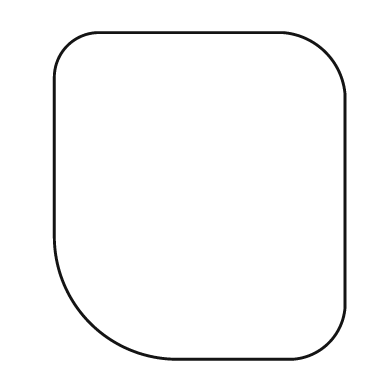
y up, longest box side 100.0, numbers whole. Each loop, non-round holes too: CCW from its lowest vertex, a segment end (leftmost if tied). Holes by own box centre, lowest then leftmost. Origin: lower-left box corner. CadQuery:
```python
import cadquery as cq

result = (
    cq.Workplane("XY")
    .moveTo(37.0, 0.0)
    .lineTo(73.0, 0.0)
    .threePointArc((84.0, 5.0), (89.0, 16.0))
    .lineTo(89.0, 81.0)
    .threePointArc((83.0, 94.0), (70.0, 100.0))
    .lineTo(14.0, 100.0)
    .threePointArc((4.0, 96.0), (0.0, 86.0))
    .lineTo(0.0, 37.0)
    .threePointArc((11.0, 11.0), (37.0, 0.0))
    .close()
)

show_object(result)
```